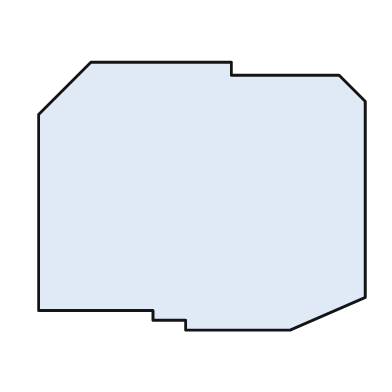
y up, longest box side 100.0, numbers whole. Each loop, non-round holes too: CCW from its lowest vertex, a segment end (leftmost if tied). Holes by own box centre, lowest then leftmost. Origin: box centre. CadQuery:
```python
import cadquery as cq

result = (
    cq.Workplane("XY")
    .moveTo(-5.0, -41.0)
    .lineTo(27.0, -41.0)
    .lineTo(50.0, -31.0)
    .lineTo(50.0, 29.0)
    .lineTo(42.0, 37.0)
    .lineTo(9.0, 37.0)
    .lineTo(9.0, 41.0)
    .lineTo(-34.0, 41.0)
    .lineTo(-50.0, 25.0)
    .lineTo(-50.0, -35.0)
    .lineTo(-15.0, -35.0)
    .lineTo(-15.0, -38.0)
    .lineTo(-5.0, -38.0)
    .close()
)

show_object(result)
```